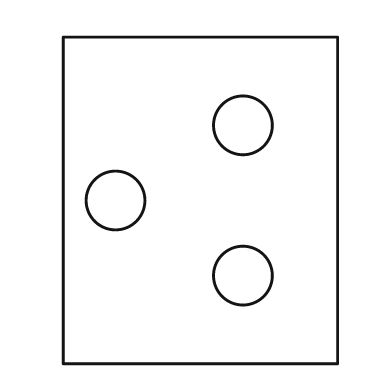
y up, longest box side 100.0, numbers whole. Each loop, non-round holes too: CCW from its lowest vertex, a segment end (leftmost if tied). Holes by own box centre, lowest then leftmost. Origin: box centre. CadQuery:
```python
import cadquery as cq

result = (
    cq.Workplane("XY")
    .moveTo(-42.0, -50.0)
    .lineTo(42.0, -50.0)
    .lineTo(42.0, 50.0)
    .lineTo(-42.0, 50.0)
    .close()
    .moveTo(13.0, -23.0)
    .circle(9.0)
    .moveTo(-26.0, 0.0)
    .circle(9.0)
    .moveTo(13.0, 23.0)
    .circle(9.0)
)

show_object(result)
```